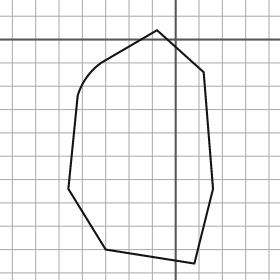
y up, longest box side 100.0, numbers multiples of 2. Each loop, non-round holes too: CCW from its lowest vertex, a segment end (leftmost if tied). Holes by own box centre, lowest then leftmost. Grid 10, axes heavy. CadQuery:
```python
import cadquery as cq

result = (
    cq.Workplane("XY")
    .moveTo(8.0, -96.0)
    .lineTo(16.0, -64.0)
    .lineTo(12.0, -14.0)
    .lineTo(-8.0, 4.0)
    .lineTo(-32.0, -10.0)
    .threePointArc((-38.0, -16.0), (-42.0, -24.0))
    .lineTo(-46.0, -64.0)
    .lineTo(-30.0, -90.0)
    .close()
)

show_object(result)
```